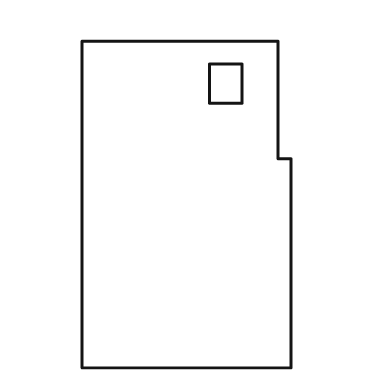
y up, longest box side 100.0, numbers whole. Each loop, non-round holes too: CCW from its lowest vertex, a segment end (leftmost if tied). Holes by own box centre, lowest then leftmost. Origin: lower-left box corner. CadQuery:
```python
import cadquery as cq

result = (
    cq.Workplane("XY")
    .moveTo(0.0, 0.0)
    .lineTo(64.0, 0.0)
    .lineTo(64.0, 64.0)
    .lineTo(60.0, 64.0)
    .lineTo(60.0, 100.0)
    .lineTo(0.0, 100.0)
    .close()
    .moveTo(39.0, 81.0)
    .lineTo(49.0, 81.0)
    .lineTo(49.0, 93.0)
    .lineTo(39.0, 93.0)
    .close()
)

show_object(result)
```